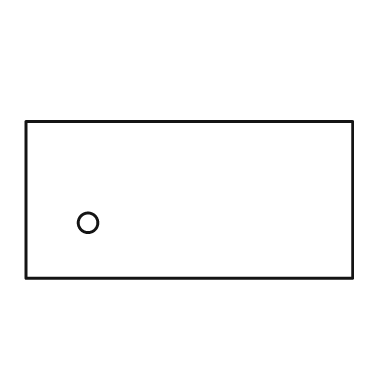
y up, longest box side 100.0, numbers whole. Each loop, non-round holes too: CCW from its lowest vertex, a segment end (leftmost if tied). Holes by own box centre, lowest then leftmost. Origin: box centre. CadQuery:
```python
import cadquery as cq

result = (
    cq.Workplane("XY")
    .moveTo(-50.0, -24.0)
    .lineTo(50.0, -24.0)
    .lineTo(50.0, 24.0)
    .lineTo(-50.0, 24.0)
    .close()
    .moveTo(-31.0, -7.0)
    .circle(3.0)
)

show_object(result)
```